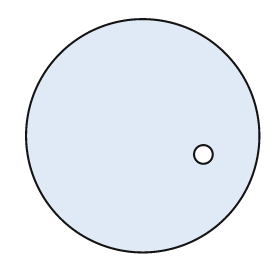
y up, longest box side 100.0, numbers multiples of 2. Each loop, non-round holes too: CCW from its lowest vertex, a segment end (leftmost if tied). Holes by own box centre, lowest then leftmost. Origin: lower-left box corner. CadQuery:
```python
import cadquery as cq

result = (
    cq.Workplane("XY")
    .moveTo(50.0, 50.0)
    .circle(50.0)
    .moveTo(76.0, 42.0)
    .circle(4.0)
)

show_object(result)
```